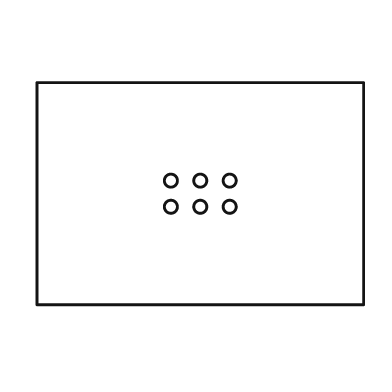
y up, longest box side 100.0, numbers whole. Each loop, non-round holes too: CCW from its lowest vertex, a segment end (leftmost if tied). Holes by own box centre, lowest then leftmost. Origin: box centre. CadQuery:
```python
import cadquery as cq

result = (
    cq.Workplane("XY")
    .moveTo(-50.0, -34.0)
    .lineTo(50.0, -34.0)
    .lineTo(50.0, 34.0)
    .lineTo(-50.0, 34.0)
    .close()
    .moveTo(-9.0, -4.0)
    .circle(2.0)
    .moveTo(0.0, -4.0)
    .circle(2.0)
    .moveTo(9.0, -4.0)
    .circle(2.0)
    .moveTo(-9.0, 4.0)
    .circle(2.0)
    .moveTo(0.0, 4.0)
    .circle(2.0)
    .moveTo(9.0, 4.0)
    .circle(2.0)
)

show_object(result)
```